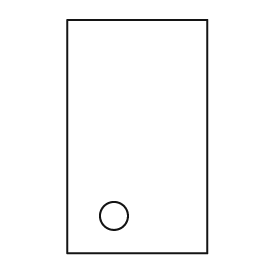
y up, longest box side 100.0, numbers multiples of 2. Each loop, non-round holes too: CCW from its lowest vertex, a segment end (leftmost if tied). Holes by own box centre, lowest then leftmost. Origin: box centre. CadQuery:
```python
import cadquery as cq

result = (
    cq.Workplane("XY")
    .moveTo(-30.0, -50.0)
    .lineTo(30.0, -50.0)
    .lineTo(30.0, 50.0)
    .lineTo(-30.0, 50.0)
    .close()
    .moveTo(-10.0, -34.0)
    .circle(6.0)
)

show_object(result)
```